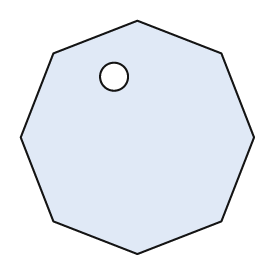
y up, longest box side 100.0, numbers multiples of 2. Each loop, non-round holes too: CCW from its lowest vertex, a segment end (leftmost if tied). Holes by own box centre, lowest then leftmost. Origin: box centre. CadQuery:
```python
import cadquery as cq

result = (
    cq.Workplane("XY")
    .moveTo(0.0, -50.0)
    .lineTo(36.0, -36.0)
    .lineTo(50.0, 0.0)
    .lineTo(36.0, 36.0)
    .lineTo(0.0, 50.0)
    .lineTo(-36.0, 36.0)
    .lineTo(-50.0, 0.0)
    .lineTo(-36.0, -36.0)
    .close()
    .moveTo(-10.0, 26.0)
    .circle(6.0)
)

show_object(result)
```